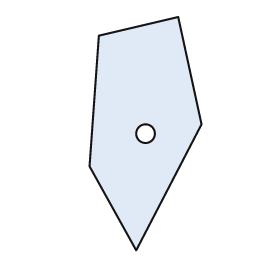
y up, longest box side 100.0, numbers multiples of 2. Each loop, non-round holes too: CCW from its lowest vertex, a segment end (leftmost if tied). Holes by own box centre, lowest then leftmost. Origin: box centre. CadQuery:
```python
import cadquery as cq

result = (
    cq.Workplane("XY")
    .moveTo(-4.0, -50.0)
    .lineTo(24.0, 4.0)
    .lineTo(14.0, 50.0)
    .lineTo(-20.0, 42.0)
    .lineTo(-24.0, -14.0)
    .close()
    .moveTo(0.0, 0.0)
    .circle(4.0)
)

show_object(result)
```